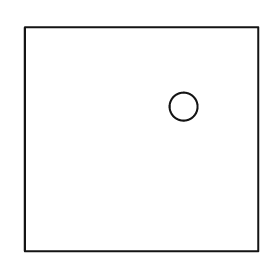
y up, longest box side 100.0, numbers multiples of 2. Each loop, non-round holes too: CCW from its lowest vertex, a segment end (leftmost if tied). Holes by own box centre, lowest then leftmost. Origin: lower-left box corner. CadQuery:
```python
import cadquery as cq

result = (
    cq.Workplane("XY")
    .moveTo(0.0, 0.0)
    .lineTo(100.0, 0.0)
    .lineTo(100.0, 96.0)
    .lineTo(0.0, 96.0)
    .close()
    .moveTo(68.0, 62.0)
    .circle(6.0)
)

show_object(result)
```